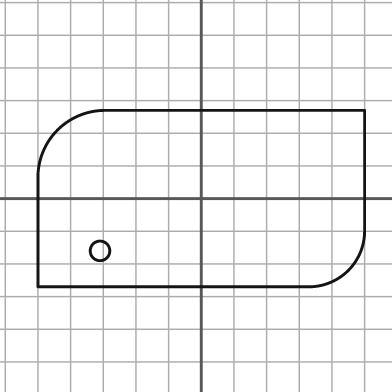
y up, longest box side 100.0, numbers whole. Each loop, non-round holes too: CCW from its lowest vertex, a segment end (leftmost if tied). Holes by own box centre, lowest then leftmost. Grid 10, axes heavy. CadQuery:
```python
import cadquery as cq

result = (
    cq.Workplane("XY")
    .moveTo(-50.0, -27.0)
    .lineTo(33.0, -27.0)
    .threePointArc((45.0, -22.0), (50.0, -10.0))
    .lineTo(50.0, 27.0)
    .lineTo(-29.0, 27.0)
    .threePointArc((-44.0, 21.0), (-50.0, 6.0))
    .close()
    .moveTo(-31.0, -16.0)
    .circle(3.0)
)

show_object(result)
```